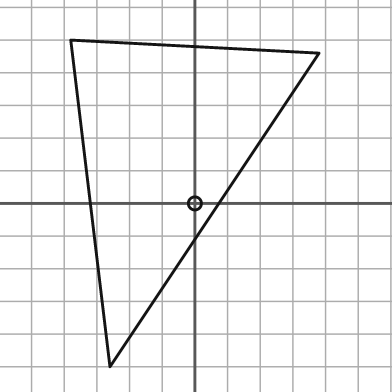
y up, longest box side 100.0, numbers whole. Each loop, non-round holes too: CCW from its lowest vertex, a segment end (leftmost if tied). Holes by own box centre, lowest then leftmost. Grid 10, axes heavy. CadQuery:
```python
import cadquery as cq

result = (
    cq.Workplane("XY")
    .moveTo(-26.0, -50.0)
    .lineTo(38.0, 46.0)
    .lineTo(-38.0, 50.0)
    .close()
    .moveTo(0.0, 0.0)
    .circle(2.0)
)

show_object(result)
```